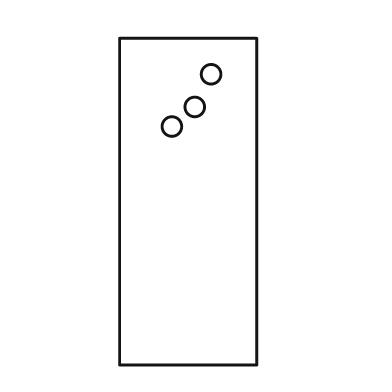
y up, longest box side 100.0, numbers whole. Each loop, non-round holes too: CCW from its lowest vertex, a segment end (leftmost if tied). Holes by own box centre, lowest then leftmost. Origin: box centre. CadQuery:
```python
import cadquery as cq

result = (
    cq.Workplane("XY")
    .moveTo(-21.0, -50.0)
    .lineTo(21.0, -50.0)
    .lineTo(21.0, 50.0)
    .lineTo(-21.0, 50.0)
    .close()
    .moveTo(-5.0, 23.0)
    .circle(3.0)
    .moveTo(2.0, 29.0)
    .circle(3.0)
    .moveTo(7.0, 39.0)
    .circle(3.0)
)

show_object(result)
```